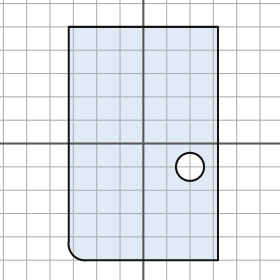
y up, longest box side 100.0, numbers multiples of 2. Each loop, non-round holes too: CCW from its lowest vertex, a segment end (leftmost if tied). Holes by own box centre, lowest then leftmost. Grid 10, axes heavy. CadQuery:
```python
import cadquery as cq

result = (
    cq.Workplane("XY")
    .moveTo(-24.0, -50.0)
    .lineTo(32.0, -50.0)
    .lineTo(32.0, 50.0)
    .lineTo(-32.0, 50.0)
    .lineTo(-32.0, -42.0)
    .threePointArc((-30.0, -48.0), (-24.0, -50.0))
    .close()
    .moveTo(20.0, -10.0)
    .circle(6.0)
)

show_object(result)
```